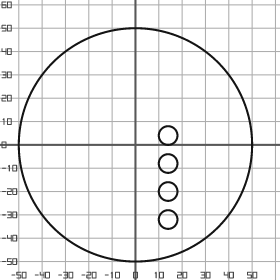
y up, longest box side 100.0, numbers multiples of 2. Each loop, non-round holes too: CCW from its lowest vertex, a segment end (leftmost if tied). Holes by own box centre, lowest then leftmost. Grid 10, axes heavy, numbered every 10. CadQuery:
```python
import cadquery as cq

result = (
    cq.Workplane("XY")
    .moveTo(0.0, 0.0)
    .circle(50.0)
    .moveTo(14.0, -32.0)
    .circle(4.0)
    .moveTo(14.0, -20.0)
    .circle(4.0)
    .moveTo(14.0, -8.0)
    .circle(4.0)
    .moveTo(14.0, 4.0)
    .circle(4.0)
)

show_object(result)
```